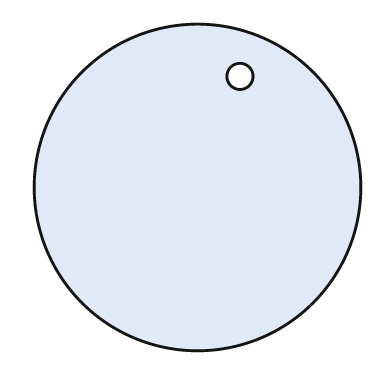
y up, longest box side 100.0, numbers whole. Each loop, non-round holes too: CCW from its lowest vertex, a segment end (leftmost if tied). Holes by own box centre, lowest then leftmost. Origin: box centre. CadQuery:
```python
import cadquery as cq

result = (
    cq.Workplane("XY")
    .moveTo(0.0, 0.0)
    .circle(50.0)
    .moveTo(13.0, 34.0)
    .circle(4.0)
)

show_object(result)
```